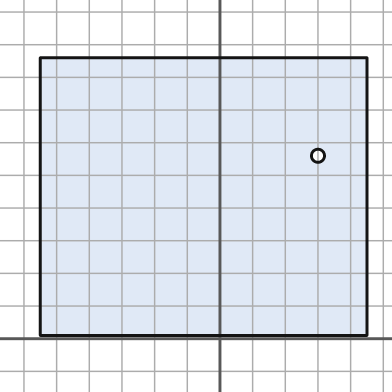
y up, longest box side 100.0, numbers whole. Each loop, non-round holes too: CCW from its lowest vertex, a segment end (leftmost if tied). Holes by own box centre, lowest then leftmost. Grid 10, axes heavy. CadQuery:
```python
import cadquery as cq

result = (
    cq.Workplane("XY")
    .moveTo(-55.0, 1.0)
    .lineTo(45.0, 1.0)
    .lineTo(45.0, 86.0)
    .lineTo(-55.0, 86.0)
    .close()
    .moveTo(30.0, 56.0)
    .circle(2.0)
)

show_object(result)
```